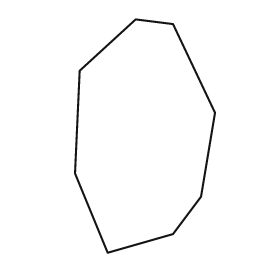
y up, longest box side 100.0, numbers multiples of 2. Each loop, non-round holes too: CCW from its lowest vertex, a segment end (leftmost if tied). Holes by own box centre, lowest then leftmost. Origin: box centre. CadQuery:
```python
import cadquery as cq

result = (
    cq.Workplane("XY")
    .moveTo(-16.0, -50.0)
    .lineTo(12.0, -42.0)
    .lineTo(24.0, -26.0)
    .lineTo(30.0, 10.0)
    .lineTo(12.0, 48.0)
    .lineTo(-4.0, 50.0)
    .lineTo(-28.0, 28.0)
    .lineTo(-30.0, -16.0)
    .close()
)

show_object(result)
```